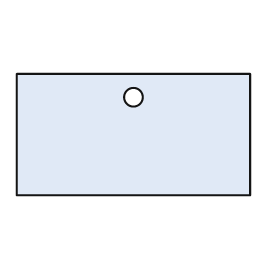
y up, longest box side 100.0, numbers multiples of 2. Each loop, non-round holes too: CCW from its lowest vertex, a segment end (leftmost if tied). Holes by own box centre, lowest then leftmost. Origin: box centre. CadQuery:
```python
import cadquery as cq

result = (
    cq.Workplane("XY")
    .moveTo(-50.0, -26.0)
    .lineTo(50.0, -26.0)
    .lineTo(50.0, 26.0)
    .lineTo(-50.0, 26.0)
    .close()
    .moveTo(0.0, 16.0)
    .circle(4.0)
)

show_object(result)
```